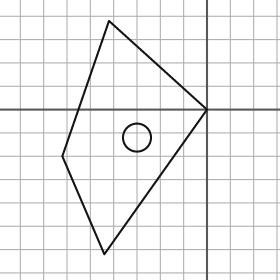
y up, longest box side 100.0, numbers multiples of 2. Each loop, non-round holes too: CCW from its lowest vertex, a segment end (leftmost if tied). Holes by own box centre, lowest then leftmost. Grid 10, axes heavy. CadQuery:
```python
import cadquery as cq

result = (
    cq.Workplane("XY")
    .moveTo(-44.0, -62.0)
    .lineTo(0.0, 0.0)
    .lineTo(-42.0, 38.0)
    .lineTo(-62.0, -20.0)
    .close()
    .moveTo(-30.0, -12.0)
    .circle(6.0)
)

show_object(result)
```